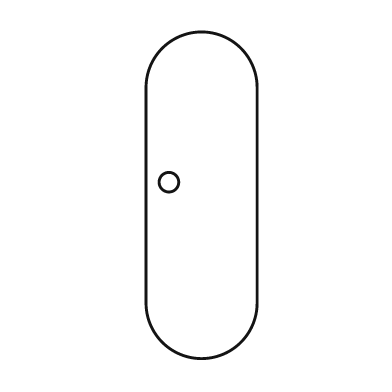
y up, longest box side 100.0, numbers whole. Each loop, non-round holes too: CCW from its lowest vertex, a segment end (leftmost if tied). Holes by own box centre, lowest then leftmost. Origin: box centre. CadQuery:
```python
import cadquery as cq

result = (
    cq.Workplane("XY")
    .moveTo(-17.0, -33.0)
    .threePointArc((0.0, -50.0), (17.0, -33.0))
    .lineTo(17.0, 33.0)
    .threePointArc((0.0, 50.0), (-17.0, 33.0))
    .close()
    .moveTo(-10.0, 4.0)
    .circle(3.0)
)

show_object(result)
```